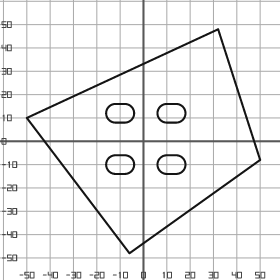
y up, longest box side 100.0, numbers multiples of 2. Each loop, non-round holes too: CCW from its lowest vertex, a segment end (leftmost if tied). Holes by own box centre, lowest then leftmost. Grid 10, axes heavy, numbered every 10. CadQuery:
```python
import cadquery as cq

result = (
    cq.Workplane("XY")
    .moveTo(-6.0, -48.0)
    .lineTo(50.0, -8.0)
    .lineTo(32.0, 48.0)
    .lineTo(-50.0, 10.0)
    .close()
    .moveTo(-12.0, -14.0)
    .lineTo(-8.0, -14.0)
    .threePointArc((-4.0, -10.0), (-8.0, -6.0))
    .lineTo(-12.0, -6.0)
    .threePointArc((-16.0, -10.0), (-12.0, -14.0))
    .close()
    .moveTo(10.0, -14.0)
    .lineTo(14.0, -14.0)
    .threePointArc((18.0, -10.0), (14.0, -6.0))
    .lineTo(10.0, -6.0)
    .threePointArc((6.0, -10.0), (10.0, -14.0))
    .close()
    .moveTo(-12.0, 8.0)
    .lineTo(-8.0, 8.0)
    .threePointArc((-4.0, 12.0), (-8.0, 16.0))
    .lineTo(-12.0, 16.0)
    .threePointArc((-16.0, 12.0), (-12.0, 8.0))
    .close()
    .moveTo(10.0, 8.0)
    .lineTo(14.0, 8.0)
    .threePointArc((18.0, 12.0), (14.0, 16.0))
    .lineTo(10.0, 16.0)
    .threePointArc((6.0, 12.0), (10.0, 8.0))
    .close()
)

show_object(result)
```